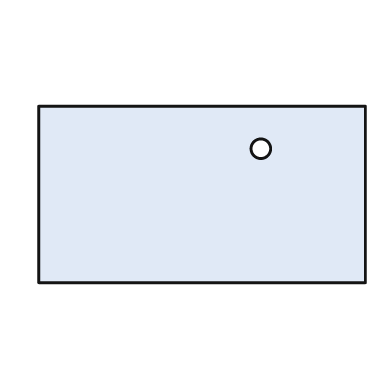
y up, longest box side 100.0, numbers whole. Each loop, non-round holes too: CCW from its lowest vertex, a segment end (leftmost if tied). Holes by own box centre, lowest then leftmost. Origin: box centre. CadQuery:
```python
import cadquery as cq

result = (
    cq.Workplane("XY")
    .moveTo(-50.0, -27.0)
    .lineTo(50.0, -27.0)
    .lineTo(50.0, 27.0)
    .lineTo(-50.0, 27.0)
    .close()
    .moveTo(18.0, 14.0)
    .circle(3.0)
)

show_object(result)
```